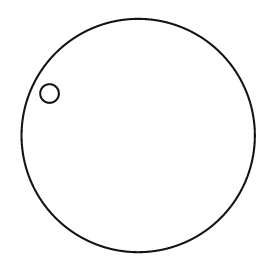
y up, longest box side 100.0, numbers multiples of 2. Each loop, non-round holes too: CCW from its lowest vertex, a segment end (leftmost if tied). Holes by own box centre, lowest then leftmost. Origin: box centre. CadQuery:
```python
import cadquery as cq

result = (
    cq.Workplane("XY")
    .moveTo(0.0, 0.0)
    .circle(50.0)
    .moveTo(-38.0, 18.0)
    .circle(4.0)
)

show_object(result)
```